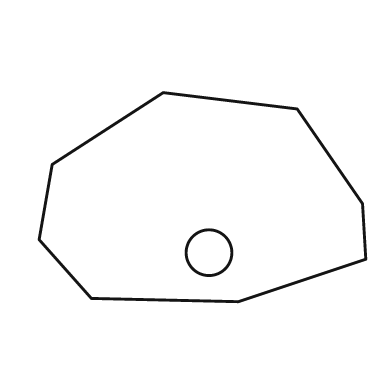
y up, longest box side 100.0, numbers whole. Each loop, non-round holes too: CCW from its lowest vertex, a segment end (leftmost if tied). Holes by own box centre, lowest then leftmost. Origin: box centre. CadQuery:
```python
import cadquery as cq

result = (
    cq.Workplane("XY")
    .moveTo(11.0, -32.0)
    .lineTo(50.0, -19.0)
    .lineTo(49.0, -2.0)
    .lineTo(29.0, 27.0)
    .lineTo(-12.0, 32.0)
    .lineTo(-46.0, 10.0)
    .lineTo(-50.0, -13.0)
    .lineTo(-34.0, -31.0)
    .close()
    .moveTo(2.0, -17.0)
    .circle(7.0)
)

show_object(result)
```